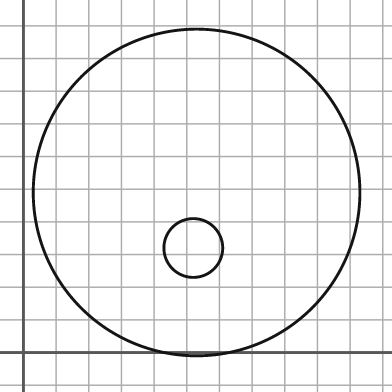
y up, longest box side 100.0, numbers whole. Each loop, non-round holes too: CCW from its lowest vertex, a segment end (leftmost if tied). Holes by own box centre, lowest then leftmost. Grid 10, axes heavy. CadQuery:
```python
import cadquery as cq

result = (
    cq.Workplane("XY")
    .moveTo(53.0, 49.0)
    .circle(50.0)
    .moveTo(52.0, 32.0)
    .circle(9.0)
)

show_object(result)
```